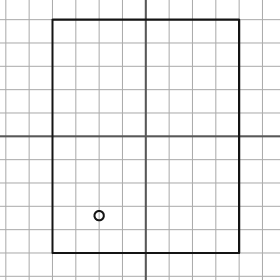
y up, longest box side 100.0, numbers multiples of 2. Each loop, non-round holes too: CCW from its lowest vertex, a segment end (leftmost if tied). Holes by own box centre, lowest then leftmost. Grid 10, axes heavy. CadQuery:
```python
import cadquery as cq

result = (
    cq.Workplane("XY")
    .moveTo(-40.0, -50.0)
    .lineTo(40.0, -50.0)
    .lineTo(40.0, 50.0)
    .lineTo(-40.0, 50.0)
    .close()
    .moveTo(-20.0, -34.0)
    .circle(2.0)
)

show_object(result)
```